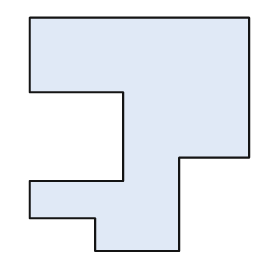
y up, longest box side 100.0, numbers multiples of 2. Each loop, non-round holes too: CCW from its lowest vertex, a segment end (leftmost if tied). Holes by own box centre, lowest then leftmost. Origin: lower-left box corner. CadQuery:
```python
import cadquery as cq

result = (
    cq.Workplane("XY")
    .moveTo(28.0, 0.0)
    .lineTo(64.0, 0.0)
    .lineTo(64.0, 40.0)
    .lineTo(94.0, 40.0)
    .lineTo(94.0, 100.0)
    .lineTo(0.0, 100.0)
    .lineTo(0.0, 68.0)
    .lineTo(40.0, 68.0)
    .lineTo(40.0, 30.0)
    .lineTo(0.0, 30.0)
    .lineTo(0.0, 14.0)
    .lineTo(28.0, 14.0)
    .close()
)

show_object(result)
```